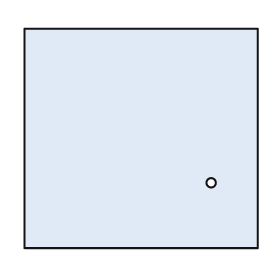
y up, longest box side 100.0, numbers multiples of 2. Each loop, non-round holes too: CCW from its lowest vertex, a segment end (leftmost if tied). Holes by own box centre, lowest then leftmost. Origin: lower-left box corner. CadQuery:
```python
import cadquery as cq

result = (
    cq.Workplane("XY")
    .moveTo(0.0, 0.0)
    .lineTo(100.0, 0.0)
    .lineTo(100.0, 94.0)
    .lineTo(0.0, 94.0)
    .close()
    .moveTo(80.0, 28.0)
    .circle(2.0)
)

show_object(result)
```